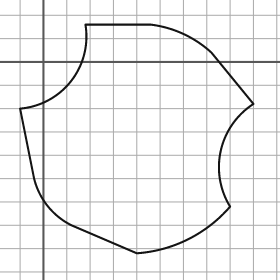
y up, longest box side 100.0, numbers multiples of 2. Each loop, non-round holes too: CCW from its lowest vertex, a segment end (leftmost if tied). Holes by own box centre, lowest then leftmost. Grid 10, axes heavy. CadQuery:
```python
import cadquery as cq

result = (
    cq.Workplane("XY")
    .moveTo(40.0, -82.0)
    .threePointArc((62.0, -76.0), (80.0, -62.0))
    .threePointArc((76.0, -38.0), (90.0, -18.0))
    .lineTo(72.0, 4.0)
    .threePointArc((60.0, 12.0), (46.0, 16.0))
    .lineTo(18.0, 16.0)
    .threePointArc((12.0, -8.0), (-10.0, -20.0))
    .lineTo(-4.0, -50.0)
    .threePointArc((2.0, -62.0), (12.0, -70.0))
    .close()
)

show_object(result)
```